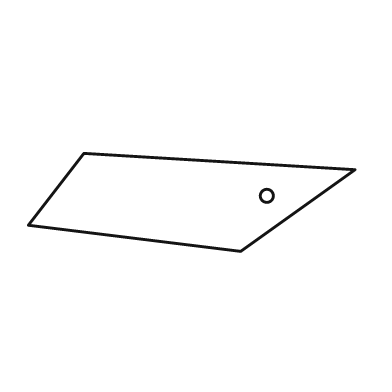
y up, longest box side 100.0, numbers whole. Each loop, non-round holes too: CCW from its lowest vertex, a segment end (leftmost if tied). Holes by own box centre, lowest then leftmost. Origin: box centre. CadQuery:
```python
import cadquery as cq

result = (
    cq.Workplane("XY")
    .moveTo(15.0, -15.0)
    .lineTo(50.0, 10.0)
    .lineTo(-33.0, 15.0)
    .lineTo(-50.0, -7.0)
    .close()
    .moveTo(23.0, 2.0)
    .circle(2.0)
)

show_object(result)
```